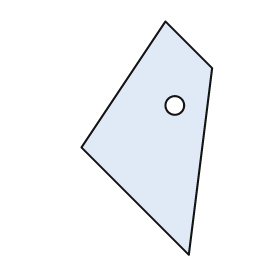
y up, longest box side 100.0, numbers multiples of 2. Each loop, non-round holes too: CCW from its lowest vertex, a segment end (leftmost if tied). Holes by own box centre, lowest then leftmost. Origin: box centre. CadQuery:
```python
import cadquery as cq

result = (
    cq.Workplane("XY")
    .moveTo(18.0, -50.0)
    .lineTo(28.0, 30.0)
    .lineTo(8.0, 50.0)
    .lineTo(-28.0, -4.0)
    .close()
    .moveTo(12.0, 14.0)
    .circle(4.0)
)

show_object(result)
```